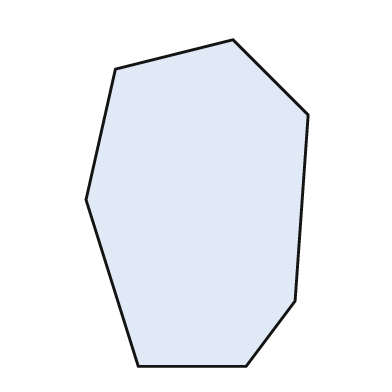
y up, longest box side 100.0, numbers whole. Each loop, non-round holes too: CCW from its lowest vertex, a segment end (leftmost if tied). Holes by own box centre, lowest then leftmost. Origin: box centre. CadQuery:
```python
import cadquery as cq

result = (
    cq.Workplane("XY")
    .moveTo(-18.0, -50.0)
    .lineTo(15.0, -50.0)
    .lineTo(30.0, -30.0)
    .lineTo(34.0, 27.0)
    .lineTo(11.0, 50.0)
    .lineTo(-25.0, 41.0)
    .lineTo(-34.0, 1.0)
    .close()
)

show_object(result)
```